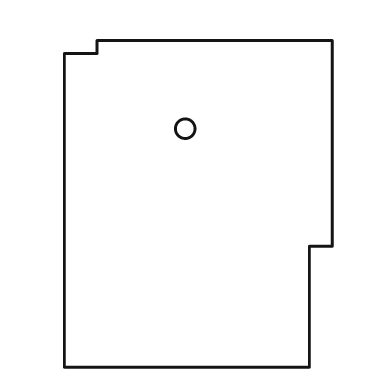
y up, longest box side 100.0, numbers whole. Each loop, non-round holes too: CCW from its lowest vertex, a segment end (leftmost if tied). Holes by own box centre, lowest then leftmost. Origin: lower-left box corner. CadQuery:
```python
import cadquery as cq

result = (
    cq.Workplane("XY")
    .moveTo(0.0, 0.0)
    .lineTo(75.0, 0.0)
    .lineTo(75.0, 37.0)
    .lineTo(82.0, 37.0)
    .lineTo(82.0, 100.0)
    .lineTo(10.0, 100.0)
    .lineTo(10.0, 96.0)
    .lineTo(0.0, 96.0)
    .close()
    .moveTo(37.0, 73.0)
    .circle(3.0)
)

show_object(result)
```